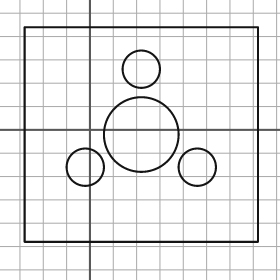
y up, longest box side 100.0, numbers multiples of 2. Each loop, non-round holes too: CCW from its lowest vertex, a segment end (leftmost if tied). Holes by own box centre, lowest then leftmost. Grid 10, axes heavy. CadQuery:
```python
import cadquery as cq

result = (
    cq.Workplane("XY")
    .moveTo(-28.0, -48.0)
    .lineTo(72.0, -48.0)
    .lineTo(72.0, 44.0)
    .lineTo(-28.0, 44.0)
    .close()
    .moveTo(-2.0, -16.0)
    .circle(8.0)
    .moveTo(46.0, -16.0)
    .circle(8.0)
    .moveTo(22.0, -2.0)
    .circle(16.0)
    .moveTo(22.0, 26.0)
    .circle(8.0)
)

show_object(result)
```